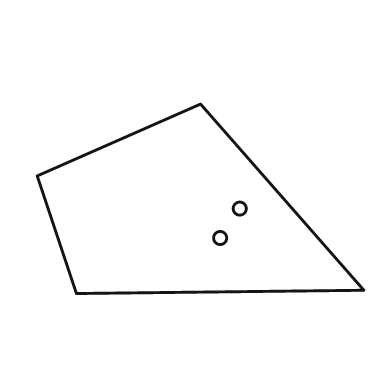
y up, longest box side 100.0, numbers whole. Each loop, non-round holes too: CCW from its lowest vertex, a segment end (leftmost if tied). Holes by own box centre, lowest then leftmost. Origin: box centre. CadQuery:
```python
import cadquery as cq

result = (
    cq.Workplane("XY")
    .moveTo(-38.0, -29.0)
    .lineTo(50.0, -28.0)
    .lineTo(0.0, 29.0)
    .lineTo(-50.0, 7.0)
    .close()
    .moveTo(6.0, -12.0)
    .circle(2.0)
    .moveTo(12.0, -3.0)
    .circle(2.0)
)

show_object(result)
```